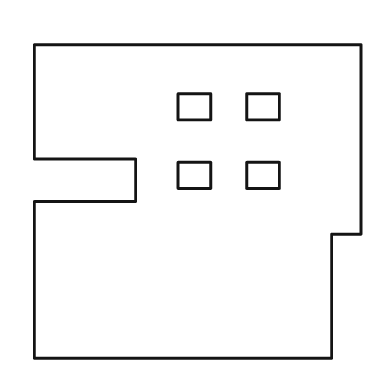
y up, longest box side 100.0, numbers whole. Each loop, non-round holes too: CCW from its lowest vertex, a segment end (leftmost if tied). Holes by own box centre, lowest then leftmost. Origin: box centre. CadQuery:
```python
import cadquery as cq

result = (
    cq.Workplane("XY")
    .moveTo(-50.0, -48.0)
    .lineTo(41.0, -48.0)
    .lineTo(41.0, -10.0)
    .lineTo(50.0, -10.0)
    .lineTo(50.0, 48.0)
    .lineTo(-50.0, 48.0)
    .lineTo(-50.0, 13.0)
    .lineTo(-19.0, 13.0)
    .lineTo(-19.0, 0.0)
    .lineTo(-50.0, 0.0)
    .close()
    .moveTo(-6.0, 4.0)
    .lineTo(4.0, 4.0)
    .lineTo(4.0, 12.0)
    .lineTo(-6.0, 12.0)
    .close()
    .moveTo(15.0, 4.0)
    .lineTo(25.0, 4.0)
    .lineTo(25.0, 12.0)
    .lineTo(15.0, 12.0)
    .close()
    .moveTo(-6.0, 25.0)
    .lineTo(4.0, 25.0)
    .lineTo(4.0, 33.0)
    .lineTo(-6.0, 33.0)
    .close()
    .moveTo(15.0, 25.0)
    .lineTo(25.0, 25.0)
    .lineTo(25.0, 33.0)
    .lineTo(15.0, 33.0)
    .close()
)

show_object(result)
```